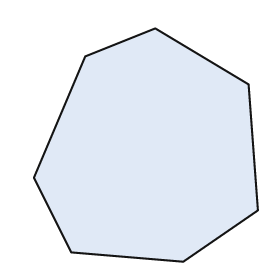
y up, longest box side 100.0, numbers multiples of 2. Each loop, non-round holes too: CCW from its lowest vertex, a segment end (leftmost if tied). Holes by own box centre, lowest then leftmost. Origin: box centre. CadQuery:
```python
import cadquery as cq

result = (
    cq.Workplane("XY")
    .moveTo(16.0, -50.0)
    .lineTo(48.0, -28.0)
    .lineTo(44.0, 26.0)
    .lineTo(4.0, 50.0)
    .lineTo(-26.0, 38.0)
    .lineTo(-48.0, -14.0)
    .lineTo(-32.0, -46.0)
    .close()
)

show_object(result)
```